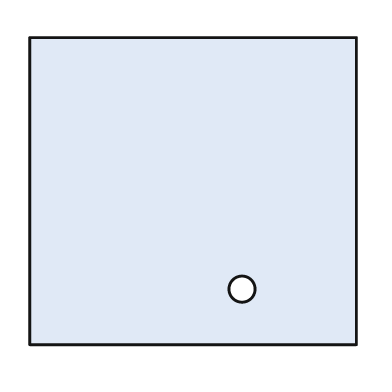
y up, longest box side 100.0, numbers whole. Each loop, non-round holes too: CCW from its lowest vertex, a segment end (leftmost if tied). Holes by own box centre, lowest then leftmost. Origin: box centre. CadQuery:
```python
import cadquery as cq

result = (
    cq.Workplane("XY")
    .moveTo(-50.0, -47.0)
    .lineTo(50.0, -47.0)
    .lineTo(50.0, 47.0)
    .lineTo(-50.0, 47.0)
    .close()
    .moveTo(15.0, -30.0)
    .circle(4.0)
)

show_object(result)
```